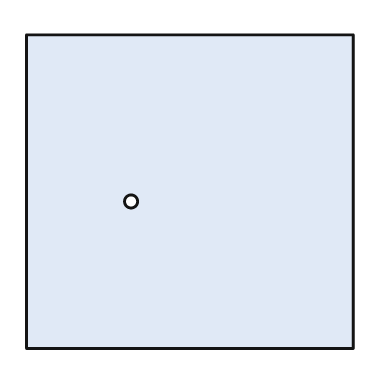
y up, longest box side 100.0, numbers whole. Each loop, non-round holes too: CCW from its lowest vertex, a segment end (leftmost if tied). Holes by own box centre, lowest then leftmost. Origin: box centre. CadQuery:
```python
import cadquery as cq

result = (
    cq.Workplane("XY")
    .moveTo(-50.0, -48.0)
    .lineTo(50.0, -48.0)
    .lineTo(50.0, 48.0)
    .lineTo(-50.0, 48.0)
    .close()
    .moveTo(-18.0, -3.0)
    .circle(2.0)
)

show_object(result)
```